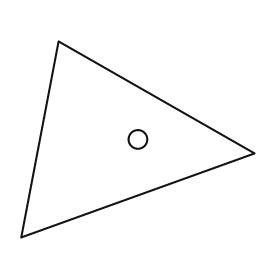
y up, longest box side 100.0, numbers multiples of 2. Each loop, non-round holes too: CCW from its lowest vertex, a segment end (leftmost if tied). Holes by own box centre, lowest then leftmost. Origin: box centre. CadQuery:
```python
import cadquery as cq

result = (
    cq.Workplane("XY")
    .moveTo(-50.0, -42.0)
    .lineTo(50.0, -6.0)
    .lineTo(-34.0, 42.0)
    .close()
    .moveTo(0.0, 0.0)
    .circle(4.0)
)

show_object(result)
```